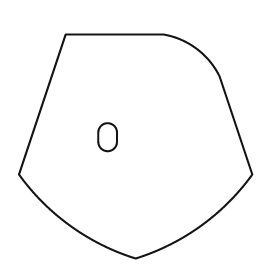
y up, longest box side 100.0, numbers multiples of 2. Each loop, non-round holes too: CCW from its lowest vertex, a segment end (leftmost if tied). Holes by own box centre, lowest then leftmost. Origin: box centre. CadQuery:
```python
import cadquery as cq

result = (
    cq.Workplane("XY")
    .moveTo(0.0, -48.0)
    .threePointArc((28.0, -34.0), (50.0, -12.0))
    .lineTo(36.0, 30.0)
    .threePointArc((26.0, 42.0), (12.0, 48.0))
    .lineTo(-30.0, 48.0)
    .lineTo(-50.0, -12.0)
    .threePointArc((-28.0, -34.0), (0.0, -48.0))
    .close()
    .moveTo(-16.0, 2.0)
    .threePointArc((-12.0, -2.0), (-8.0, 2.0))
    .lineTo(-8.0, 6.0)
    .threePointArc((-12.0, 10.0), (-16.0, 6.0))
    .close()
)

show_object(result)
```